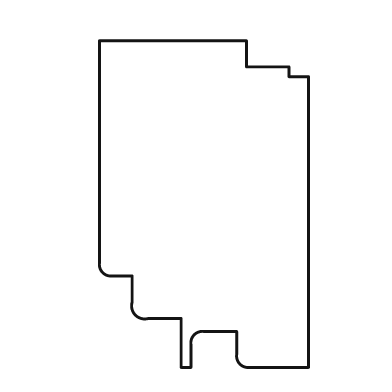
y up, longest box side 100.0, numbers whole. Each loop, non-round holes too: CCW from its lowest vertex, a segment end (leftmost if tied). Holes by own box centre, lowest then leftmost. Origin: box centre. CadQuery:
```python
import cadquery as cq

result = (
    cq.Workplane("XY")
    .moveTo(-7.0, -50.0)
    .lineTo(-4.0, -50.0)
    .lineTo(-4.0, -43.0)
    .threePointArc((-3.0, -40.0), (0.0, -39.0))
    .lineTo(10.0, -39.0)
    .lineTo(10.0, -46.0)
    .threePointArc((11.0, -49.0), (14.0, -50.0))
    .lineTo(32.0, -50.0)
    .lineTo(32.0, 39.0)
    .lineTo(26.0, 39.0)
    .lineTo(26.0, 42.0)
    .lineTo(13.0, 42.0)
    .lineTo(13.0, 50.0)
    .lineTo(-32.0, 50.0)
    .lineTo(-32.0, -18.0)
    .threePointArc((-31.0, -21.0), (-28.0, -22.0))
    .lineTo(-22.0, -22.0)
    .lineTo(-22.0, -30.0)
    .threePointArc((-21.0, -34.0), (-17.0, -35.0))
    .lineTo(-7.0, -35.0)
    .close()
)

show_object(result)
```